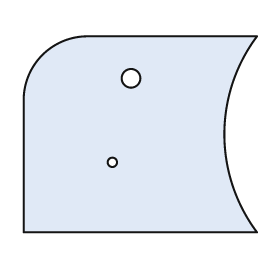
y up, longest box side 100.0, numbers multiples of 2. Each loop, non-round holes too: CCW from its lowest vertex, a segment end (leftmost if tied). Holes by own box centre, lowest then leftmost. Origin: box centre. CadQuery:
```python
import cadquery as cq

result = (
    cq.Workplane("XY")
    .moveTo(-50.0, -42.0)
    .lineTo(50.0, -42.0)
    .threePointArc((36.0, 0.0), (50.0, 42.0))
    .lineTo(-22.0, 42.0)
    .threePointArc((-42.0, 34.0), (-50.0, 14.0))
    .close()
    .moveTo(-12.0, -12.0)
    .circle(2.0)
    .moveTo(-4.0, 24.0)
    .circle(4.0)
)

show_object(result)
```